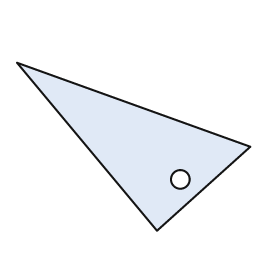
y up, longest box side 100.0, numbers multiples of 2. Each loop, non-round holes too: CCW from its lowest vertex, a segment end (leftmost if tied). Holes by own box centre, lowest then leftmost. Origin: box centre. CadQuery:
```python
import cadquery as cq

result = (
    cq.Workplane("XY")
    .moveTo(10.0, -36.0)
    .lineTo(50.0, 0.0)
    .lineTo(-50.0, 36.0)
    .close()
    .moveTo(20.0, -14.0)
    .circle(4.0)
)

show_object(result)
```